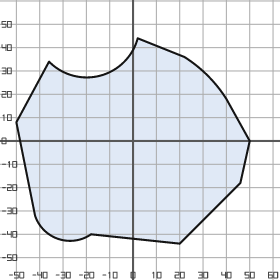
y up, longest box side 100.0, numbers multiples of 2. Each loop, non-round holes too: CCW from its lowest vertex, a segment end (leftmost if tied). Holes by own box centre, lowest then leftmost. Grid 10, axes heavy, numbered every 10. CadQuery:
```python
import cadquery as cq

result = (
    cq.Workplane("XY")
    .moveTo(20.0, -44.0)
    .lineTo(46.0, -18.0)
    .lineTo(50.0, 0.0)
    .lineTo(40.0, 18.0)
    .threePointArc((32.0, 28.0), (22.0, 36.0))
    .lineTo(2.0, 44.0)
    .threePointArc((-14.0, 28.0), (-36.0, 34.0))
    .lineTo(-50.0, 8.0)
    .lineTo(-42.0, -32.0)
    .threePointArc((-32.0, -42.0), (-18.0, -40.0))
    .close()
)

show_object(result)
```